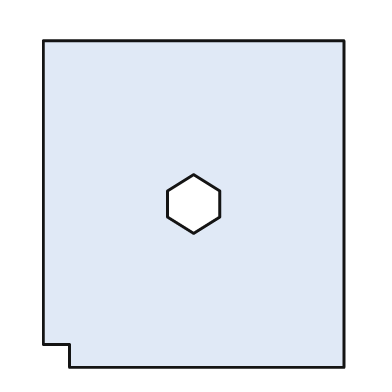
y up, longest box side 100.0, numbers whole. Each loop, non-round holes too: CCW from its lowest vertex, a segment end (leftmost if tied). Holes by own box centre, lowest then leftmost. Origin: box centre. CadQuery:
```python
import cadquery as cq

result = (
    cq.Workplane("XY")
    .moveTo(-38.0, -50.0)
    .lineTo(46.0, -50.0)
    .lineTo(46.0, 50.0)
    .lineTo(-46.0, 50.0)
    .lineTo(-46.0, -43.0)
    .lineTo(-38.0, -43.0)
    .close()
    .moveTo(0.0, -9.0)
    .lineTo(8.0, -4.0)
    .lineTo(8.0, 4.0)
    .lineTo(0.0, 9.0)
    .lineTo(-8.0, 4.0)
    .lineTo(-8.0, -4.0)
    .close()
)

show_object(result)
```